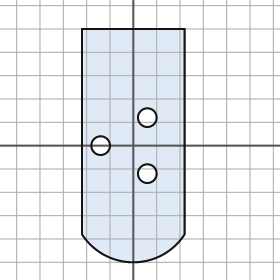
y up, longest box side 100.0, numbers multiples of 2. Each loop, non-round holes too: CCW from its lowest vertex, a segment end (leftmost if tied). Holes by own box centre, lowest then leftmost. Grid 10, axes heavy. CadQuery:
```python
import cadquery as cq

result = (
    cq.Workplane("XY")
    .moveTo(-22.0, -38.0)
    .threePointArc((0.0, -50.0), (22.0, -38.0))
    .lineTo(22.0, 50.0)
    .lineTo(-22.0, 50.0)
    .close()
    .moveTo(6.0, -12.0)
    .circle(4.0)
    .moveTo(-14.0, 0.0)
    .circle(4.0)
    .moveTo(6.0, 12.0)
    .circle(4.0)
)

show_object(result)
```